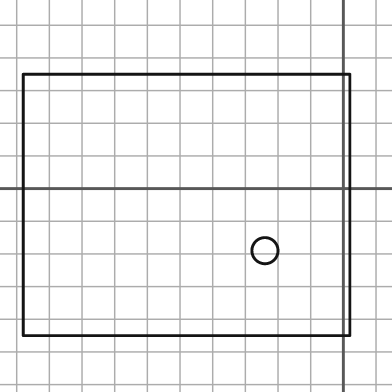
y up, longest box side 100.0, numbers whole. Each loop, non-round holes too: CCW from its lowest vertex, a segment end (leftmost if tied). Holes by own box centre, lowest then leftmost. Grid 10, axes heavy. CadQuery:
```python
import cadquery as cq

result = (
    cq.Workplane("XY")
    .moveTo(-98.0, -45.0)
    .lineTo(2.0, -45.0)
    .lineTo(2.0, 35.0)
    .lineTo(-98.0, 35.0)
    .close()
    .moveTo(-24.0, -19.0)
    .circle(4.0)
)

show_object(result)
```